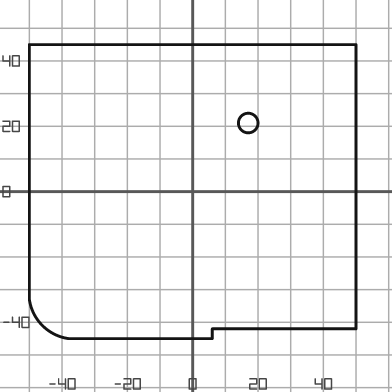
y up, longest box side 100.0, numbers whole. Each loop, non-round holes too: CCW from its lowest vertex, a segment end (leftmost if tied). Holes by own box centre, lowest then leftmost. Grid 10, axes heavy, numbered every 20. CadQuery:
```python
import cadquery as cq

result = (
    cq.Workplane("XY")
    .moveTo(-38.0, -45.0)
    .lineTo(6.0, -45.0)
    .lineTo(6.0, -42.0)
    .lineTo(50.0, -42.0)
    .lineTo(50.0, 45.0)
    .lineTo(-50.0, 45.0)
    .lineTo(-50.0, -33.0)
    .threePointArc((-46.0, -41.0), (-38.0, -45.0))
    .close()
    .moveTo(17.0, 21.0)
    .circle(3.0)
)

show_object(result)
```